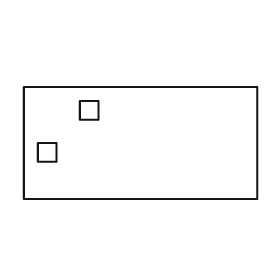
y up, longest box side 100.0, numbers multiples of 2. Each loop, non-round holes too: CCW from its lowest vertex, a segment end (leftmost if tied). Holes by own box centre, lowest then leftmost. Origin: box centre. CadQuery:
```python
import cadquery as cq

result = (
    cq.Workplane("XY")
    .moveTo(-50.0, -24.0)
    .lineTo(50.0, -24.0)
    .lineTo(50.0, 24.0)
    .lineTo(-50.0, 24.0)
    .close()
    .moveTo(-44.0, -8.0)
    .lineTo(-36.0, -8.0)
    .lineTo(-36.0, 0.0)
    .lineTo(-44.0, 0.0)
    .close()
    .moveTo(-26.0, 10.0)
    .lineTo(-18.0, 10.0)
    .lineTo(-18.0, 18.0)
    .lineTo(-26.0, 18.0)
    .close()
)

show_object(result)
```